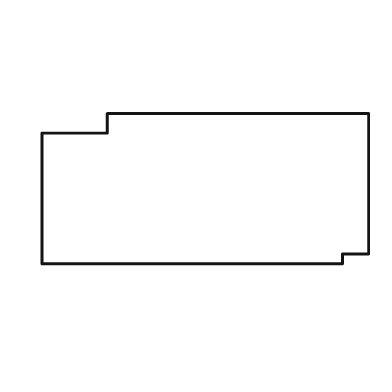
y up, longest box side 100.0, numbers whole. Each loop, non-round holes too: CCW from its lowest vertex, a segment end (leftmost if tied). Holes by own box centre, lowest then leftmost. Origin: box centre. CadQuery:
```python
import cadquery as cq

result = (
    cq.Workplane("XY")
    .moveTo(-50.0, -23.0)
    .lineTo(42.0, -23.0)
    .lineTo(42.0, -20.0)
    .lineTo(50.0, -20.0)
    .lineTo(50.0, 23.0)
    .lineTo(-30.0, 23.0)
    .lineTo(-30.0, 17.0)
    .lineTo(-50.0, 17.0)
    .close()
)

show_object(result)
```